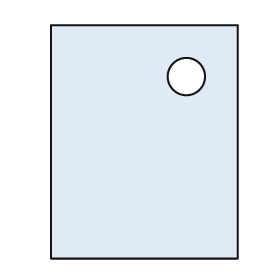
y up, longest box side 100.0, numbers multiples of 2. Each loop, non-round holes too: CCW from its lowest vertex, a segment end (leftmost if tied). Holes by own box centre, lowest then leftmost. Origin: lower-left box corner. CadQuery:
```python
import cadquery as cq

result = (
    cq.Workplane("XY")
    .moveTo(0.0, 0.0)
    .lineTo(80.0, 0.0)
    .lineTo(80.0, 100.0)
    .lineTo(0.0, 100.0)
    .close()
    .moveTo(58.0, 78.0)
    .circle(8.0)
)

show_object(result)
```